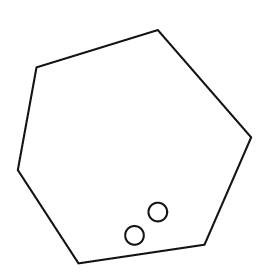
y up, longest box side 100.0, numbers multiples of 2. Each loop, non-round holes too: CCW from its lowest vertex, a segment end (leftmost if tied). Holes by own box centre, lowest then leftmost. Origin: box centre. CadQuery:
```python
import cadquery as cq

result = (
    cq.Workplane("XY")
    .moveTo(-24.0, -50.0)
    .lineTo(30.0, -42.0)
    .lineTo(50.0, 4.0)
    .lineTo(10.0, 50.0)
    .lineTo(-42.0, 34.0)
    .lineTo(-50.0, -10.0)
    .close()
    .moveTo(0.0, -38.0)
    .circle(4.0)
    .moveTo(10.0, -28.0)
    .circle(4.0)
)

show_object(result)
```